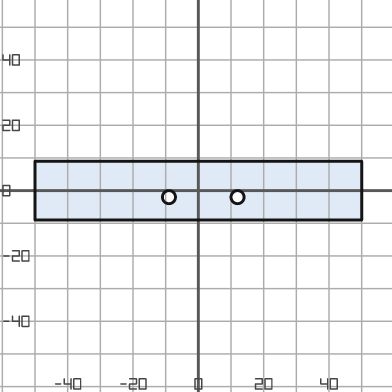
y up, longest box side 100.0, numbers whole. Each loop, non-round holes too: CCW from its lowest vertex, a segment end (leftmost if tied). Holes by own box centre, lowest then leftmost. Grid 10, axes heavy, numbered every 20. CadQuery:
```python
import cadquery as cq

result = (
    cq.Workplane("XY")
    .moveTo(-50.0, -9.0)
    .lineTo(50.0, -9.0)
    .lineTo(50.0, 9.0)
    .lineTo(-50.0, 9.0)
    .close()
    .moveTo(-9.0, -2.0)
    .circle(2.0)
    .moveTo(12.0, -2.0)
    .circle(2.0)
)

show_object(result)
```